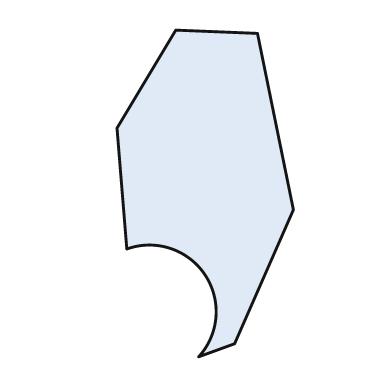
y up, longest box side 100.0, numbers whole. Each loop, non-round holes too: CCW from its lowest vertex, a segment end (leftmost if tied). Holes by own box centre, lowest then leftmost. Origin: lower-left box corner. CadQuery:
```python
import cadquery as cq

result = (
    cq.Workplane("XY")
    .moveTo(25.0, 0.0)
    .lineTo(36.0, 4.0)
    .lineTo(54.0, 45.0)
    .lineTo(43.0, 99.0)
    .lineTo(18.0, 100.0)
    .lineTo(0.0, 70.0)
    .lineTo(3.0, 33.0)
    .threePointArc((27.0, 25.0), (25.0, 0.0))
    .close()
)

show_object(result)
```